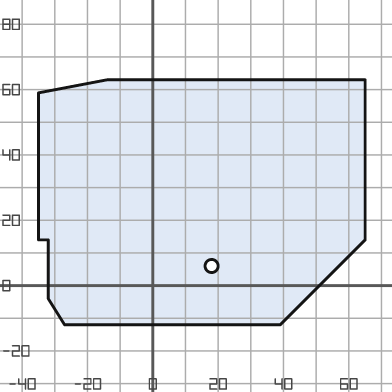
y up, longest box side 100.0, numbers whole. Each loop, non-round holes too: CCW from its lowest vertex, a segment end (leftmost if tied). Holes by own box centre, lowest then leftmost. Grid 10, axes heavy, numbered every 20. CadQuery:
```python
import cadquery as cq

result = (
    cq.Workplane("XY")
    .moveTo(-27.0, -12.0)
    .lineTo(39.0, -12.0)
    .lineTo(65.0, 14.0)
    .lineTo(65.0, 63.0)
    .lineTo(-14.0, 63.0)
    .lineTo(-35.0, 59.0)
    .lineTo(-35.0, 14.0)
    .lineTo(-32.0, 14.0)
    .lineTo(-32.0, -4.0)
    .close()
    .moveTo(18.0, 6.0)
    .circle(2.0)
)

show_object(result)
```